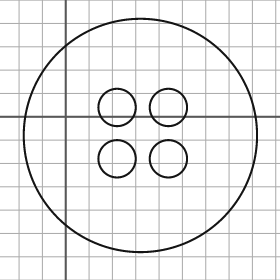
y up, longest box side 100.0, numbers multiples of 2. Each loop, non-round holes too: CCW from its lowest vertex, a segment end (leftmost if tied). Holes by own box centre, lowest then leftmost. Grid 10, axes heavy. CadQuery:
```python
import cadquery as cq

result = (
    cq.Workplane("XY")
    .moveTo(32.0, -8.0)
    .circle(50.0)
    .moveTo(22.0, -18.0)
    .circle(8.0)
    .moveTo(44.0, -18.0)
    .circle(8.0)
    .moveTo(22.0, 4.0)
    .circle(8.0)
    .moveTo(44.0, 4.0)
    .circle(8.0)
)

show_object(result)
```